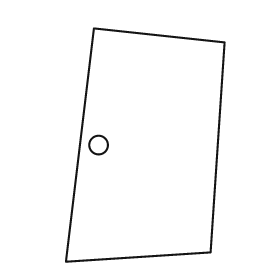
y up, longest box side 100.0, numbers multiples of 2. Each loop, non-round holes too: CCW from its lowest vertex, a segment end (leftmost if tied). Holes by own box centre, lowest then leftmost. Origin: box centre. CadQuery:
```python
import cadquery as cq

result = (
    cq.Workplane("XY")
    .moveTo(-34.0, -50.0)
    .lineTo(28.0, -46.0)
    .lineTo(34.0, 44.0)
    .lineTo(-22.0, 50.0)
    .close()
    .moveTo(-20.0, 0.0)
    .circle(4.0)
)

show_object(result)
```